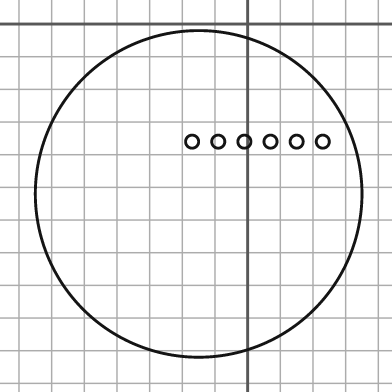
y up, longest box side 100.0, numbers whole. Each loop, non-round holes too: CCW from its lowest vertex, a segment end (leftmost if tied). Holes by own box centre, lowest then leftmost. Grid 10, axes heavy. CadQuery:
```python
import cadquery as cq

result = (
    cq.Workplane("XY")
    .moveTo(-15.0, -52.0)
    .circle(50.0)
    .moveTo(-17.0, -36.0)
    .circle(2.0)
    .moveTo(-9.0, -36.0)
    .circle(2.0)
    .moveTo(-1.0, -36.0)
    .circle(2.0)
    .moveTo(7.0, -36.0)
    .circle(2.0)
    .moveTo(15.0, -36.0)
    .circle(2.0)
    .moveTo(23.0, -36.0)
    .circle(2.0)
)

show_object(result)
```